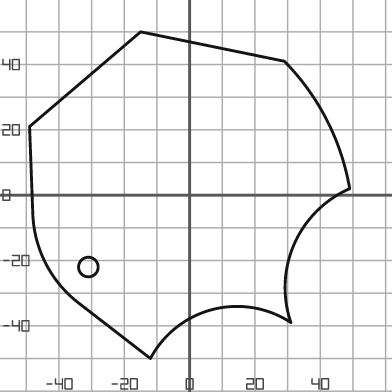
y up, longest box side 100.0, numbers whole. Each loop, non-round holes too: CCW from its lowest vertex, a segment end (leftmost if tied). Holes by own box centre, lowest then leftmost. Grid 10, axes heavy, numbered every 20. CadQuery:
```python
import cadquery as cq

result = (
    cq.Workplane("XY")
    .moveTo(-12.0, -50.0)
    .threePointArc((7.0, -35.0), (31.0, -39.0))
    .threePointArc((32.0, -15.0), (49.0, 2.0))
    .threePointArc((42.0, 23.0), (29.0, 41.0))
    .lineTo(-15.0, 50.0)
    .lineTo(-49.0, 21.0)
    .lineTo(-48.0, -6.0)
    .threePointArc((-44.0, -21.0), (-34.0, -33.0))
    .close()
    .moveTo(-31.0, -22.0)
    .circle(3.0)
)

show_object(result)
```